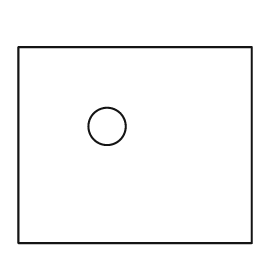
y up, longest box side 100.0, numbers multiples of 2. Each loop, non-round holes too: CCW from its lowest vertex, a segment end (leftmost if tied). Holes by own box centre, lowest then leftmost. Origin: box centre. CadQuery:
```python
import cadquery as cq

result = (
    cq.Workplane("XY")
    .moveTo(-50.0, -42.0)
    .lineTo(50.0, -42.0)
    .lineTo(50.0, 42.0)
    .lineTo(-50.0, 42.0)
    .close()
    .moveTo(-12.0, 8.0)
    .circle(8.0)
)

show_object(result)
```